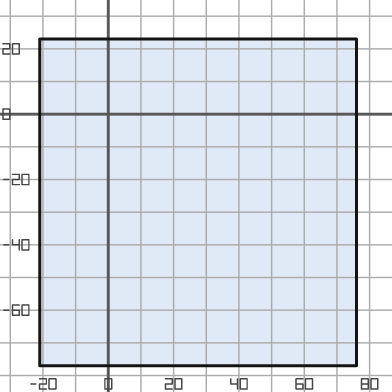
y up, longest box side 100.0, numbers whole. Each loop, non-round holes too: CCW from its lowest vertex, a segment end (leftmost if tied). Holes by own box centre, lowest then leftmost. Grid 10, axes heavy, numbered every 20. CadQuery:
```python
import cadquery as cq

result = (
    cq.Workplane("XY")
    .moveTo(-21.0, -77.0)
    .lineTo(76.0, -77.0)
    .lineTo(76.0, 23.0)
    .lineTo(-21.0, 23.0)
    .close()
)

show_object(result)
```